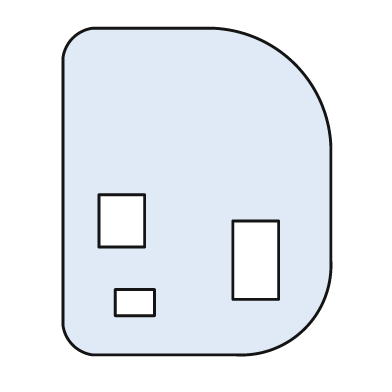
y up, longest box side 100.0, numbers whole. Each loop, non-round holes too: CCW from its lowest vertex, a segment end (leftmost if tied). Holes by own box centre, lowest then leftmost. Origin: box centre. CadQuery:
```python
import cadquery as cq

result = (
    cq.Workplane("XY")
    .moveTo(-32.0, -50.0)
    .lineTo(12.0, -50.0)
    .threePointArc((33.0, -42.0), (41.0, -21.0))
    .lineTo(41.0, 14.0)
    .threePointArc((30.0, 39.0), (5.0, 50.0))
    .lineTo(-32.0, 50.0)
    .threePointArc((-38.0, 47.0), (-41.0, 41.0))
    .lineTo(-41.0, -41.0)
    .threePointArc((-38.0, -47.0), (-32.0, -50.0))
    .close()
    .moveTo(-25.0, -38.0)
    .lineTo(-13.0, -38.0)
    .lineTo(-13.0, -30.0)
    .lineTo(-25.0, -30.0)
    .close()
    .moveTo(11.0, -33.0)
    .lineTo(25.0, -33.0)
    .lineTo(25.0, -9.0)
    .lineTo(11.0, -9.0)
    .close()
    .moveTo(-30.0, -17.0)
    .lineTo(-16.0, -17.0)
    .lineTo(-16.0, -1.0)
    .lineTo(-30.0, -1.0)
    .close()
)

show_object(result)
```